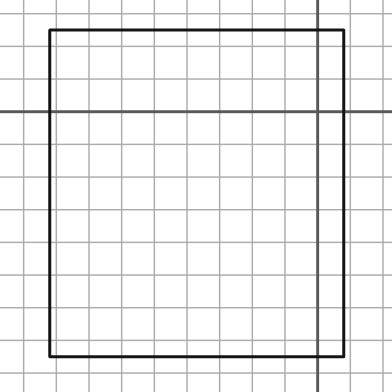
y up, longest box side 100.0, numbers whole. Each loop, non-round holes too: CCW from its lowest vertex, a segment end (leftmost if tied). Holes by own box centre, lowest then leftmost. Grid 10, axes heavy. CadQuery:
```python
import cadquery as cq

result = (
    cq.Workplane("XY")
    .moveTo(-82.0, -75.0)
    .lineTo(8.0, -75.0)
    .lineTo(8.0, 25.0)
    .lineTo(-82.0, 25.0)
    .close()
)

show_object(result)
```